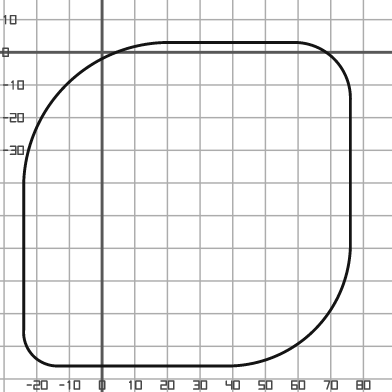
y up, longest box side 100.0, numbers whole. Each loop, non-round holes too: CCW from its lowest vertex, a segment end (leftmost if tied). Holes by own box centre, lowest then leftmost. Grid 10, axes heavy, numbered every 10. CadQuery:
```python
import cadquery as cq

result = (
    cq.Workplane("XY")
    .moveTo(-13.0, -96.0)
    .lineTo(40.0, -96.0)
    .threePointArc((65.0, -85.0), (76.0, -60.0))
    .lineTo(76.0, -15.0)
    .threePointArc((71.0, -2.0), (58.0, 3.0))
    .lineTo(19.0, 3.0)
    .threePointArc((-11.0, -10.0), (-24.0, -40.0))
    .lineTo(-24.0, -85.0)
    .threePointArc((-21.0, -93.0), (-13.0, -96.0))
    .close()
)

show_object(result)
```